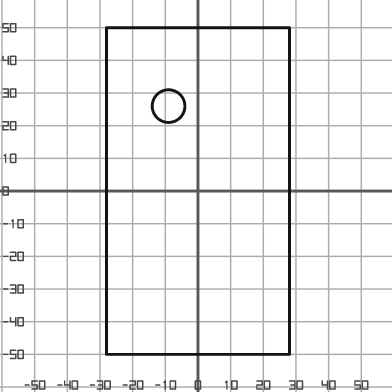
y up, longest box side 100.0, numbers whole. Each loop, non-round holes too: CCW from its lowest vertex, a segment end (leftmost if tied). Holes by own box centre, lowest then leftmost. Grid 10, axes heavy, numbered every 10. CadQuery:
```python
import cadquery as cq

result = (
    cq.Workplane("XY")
    .moveTo(-28.0, -50.0)
    .lineTo(28.0, -50.0)
    .lineTo(28.0, 50.0)
    .lineTo(-28.0, 50.0)
    .close()
    .moveTo(-9.0, 26.0)
    .circle(5.0)
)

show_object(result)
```